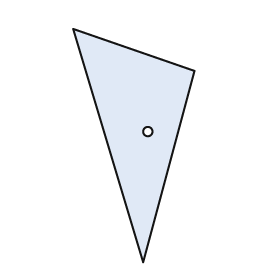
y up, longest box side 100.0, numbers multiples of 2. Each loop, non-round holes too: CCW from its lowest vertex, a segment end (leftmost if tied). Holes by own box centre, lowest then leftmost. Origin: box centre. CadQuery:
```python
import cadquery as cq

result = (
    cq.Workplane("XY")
    .moveTo(4.0, -50.0)
    .lineTo(26.0, 32.0)
    .lineTo(-26.0, 50.0)
    .close()
    .moveTo(6.0, 6.0)
    .circle(2.0)
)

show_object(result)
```